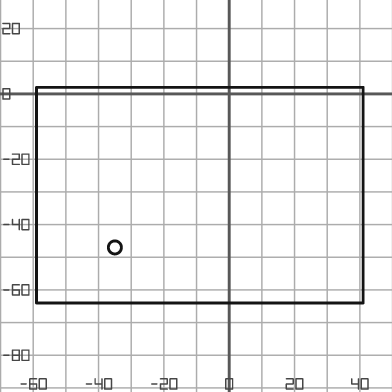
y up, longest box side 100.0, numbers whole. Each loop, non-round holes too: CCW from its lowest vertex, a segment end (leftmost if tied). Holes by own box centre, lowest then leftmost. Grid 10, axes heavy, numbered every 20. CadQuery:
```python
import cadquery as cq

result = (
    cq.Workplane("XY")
    .moveTo(-59.0, -64.0)
    .lineTo(41.0, -64.0)
    .lineTo(41.0, 2.0)
    .lineTo(-59.0, 2.0)
    .close()
    .moveTo(-35.0, -47.0)
    .circle(2.0)
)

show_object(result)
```